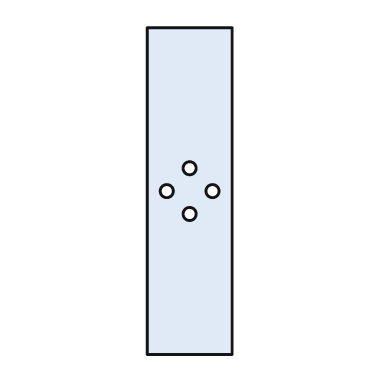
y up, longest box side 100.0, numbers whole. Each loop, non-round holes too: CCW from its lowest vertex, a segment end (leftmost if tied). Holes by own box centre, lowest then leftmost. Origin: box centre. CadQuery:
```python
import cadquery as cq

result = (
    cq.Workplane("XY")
    .moveTo(-13.0, -50.0)
    .lineTo(13.0, -50.0)
    .lineTo(13.0, 50.0)
    .lineTo(-13.0, 50.0)
    .close()
    .moveTo(0.0, -7.0)
    .circle(2.0)
    .moveTo(-7.0, 0.0)
    .circle(2.0)
    .moveTo(7.0, 0.0)
    .circle(2.0)
    .moveTo(0.0, 7.0)
    .circle(2.0)
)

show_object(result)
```